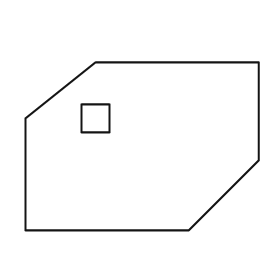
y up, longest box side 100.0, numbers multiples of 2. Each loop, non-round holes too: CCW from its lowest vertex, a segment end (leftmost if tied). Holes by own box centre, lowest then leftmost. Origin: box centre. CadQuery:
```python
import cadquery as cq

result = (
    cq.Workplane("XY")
    .moveTo(-50.0, -36.0)
    .lineTo(20.0, -36.0)
    .lineTo(50.0, -6.0)
    .lineTo(50.0, 36.0)
    .lineTo(-20.0, 36.0)
    .lineTo(-50.0, 12.0)
    .close()
    .moveTo(-26.0, 6.0)
    .lineTo(-14.0, 6.0)
    .lineTo(-14.0, 18.0)
    .lineTo(-26.0, 18.0)
    .close()
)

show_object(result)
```